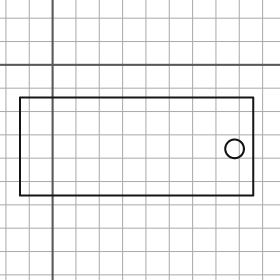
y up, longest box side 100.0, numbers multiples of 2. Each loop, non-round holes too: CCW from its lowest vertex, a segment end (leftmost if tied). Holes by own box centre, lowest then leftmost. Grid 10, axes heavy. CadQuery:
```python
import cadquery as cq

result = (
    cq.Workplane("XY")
    .moveTo(-14.0, -56.0)
    .lineTo(86.0, -56.0)
    .lineTo(86.0, -14.0)
    .lineTo(-14.0, -14.0)
    .close()
    .moveTo(78.0, -36.0)
    .circle(4.0)
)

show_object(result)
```